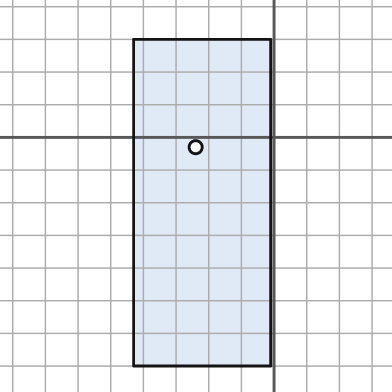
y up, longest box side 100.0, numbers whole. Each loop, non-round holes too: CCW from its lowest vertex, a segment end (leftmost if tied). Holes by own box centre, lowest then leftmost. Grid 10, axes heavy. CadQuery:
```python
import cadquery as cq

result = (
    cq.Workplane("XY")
    .moveTo(-43.0, -70.0)
    .lineTo(-1.0, -70.0)
    .lineTo(-1.0, 30.0)
    .lineTo(-43.0, 30.0)
    .close()
    .moveTo(-24.0, -3.0)
    .circle(2.0)
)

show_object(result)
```